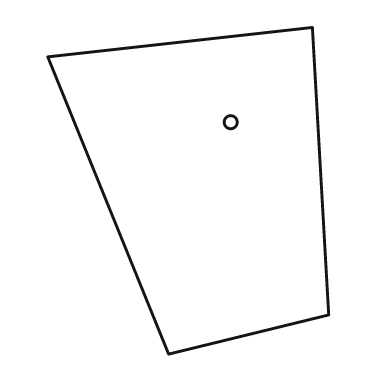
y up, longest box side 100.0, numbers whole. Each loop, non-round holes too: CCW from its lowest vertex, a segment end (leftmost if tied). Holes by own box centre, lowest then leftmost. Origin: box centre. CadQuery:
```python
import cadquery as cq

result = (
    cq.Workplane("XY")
    .moveTo(-6.0, -50.0)
    .lineTo(43.0, -38.0)
    .lineTo(38.0, 50.0)
    .lineTo(-43.0, 41.0)
    .close()
    .moveTo(13.0, 21.0)
    .circle(2.0)
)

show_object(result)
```